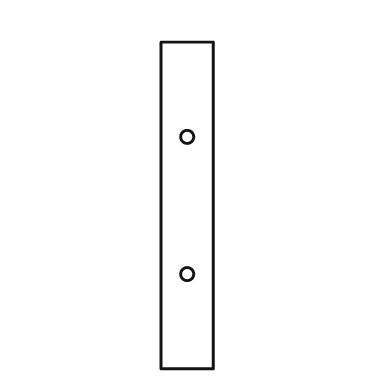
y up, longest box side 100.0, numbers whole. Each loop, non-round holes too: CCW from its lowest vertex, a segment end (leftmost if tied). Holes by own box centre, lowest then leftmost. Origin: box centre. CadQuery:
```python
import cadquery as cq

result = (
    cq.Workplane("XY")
    .moveTo(-8.0, -50.0)
    .lineTo(8.0, -50.0)
    .lineTo(8.0, 50.0)
    .lineTo(-8.0, 50.0)
    .close()
    .moveTo(0.0, -21.0)
    .circle(2.0)
    .moveTo(0.0, 21.0)
    .circle(2.0)
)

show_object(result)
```